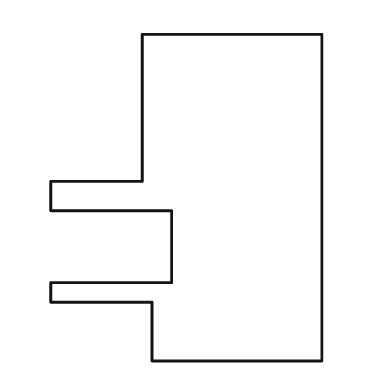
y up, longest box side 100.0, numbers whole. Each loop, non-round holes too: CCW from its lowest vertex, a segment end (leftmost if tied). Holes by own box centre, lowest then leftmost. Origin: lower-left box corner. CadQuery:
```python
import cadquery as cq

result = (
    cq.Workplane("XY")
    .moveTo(31.0, 0.0)
    .lineTo(83.0, 0.0)
    .lineTo(83.0, 100.0)
    .lineTo(28.0, 100.0)
    .lineTo(28.0, 55.0)
    .lineTo(0.0, 55.0)
    .lineTo(0.0, 46.0)
    .lineTo(37.0, 46.0)
    .lineTo(37.0, 24.0)
    .lineTo(0.0, 24.0)
    .lineTo(0.0, 18.0)
    .lineTo(31.0, 18.0)
    .close()
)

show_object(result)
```